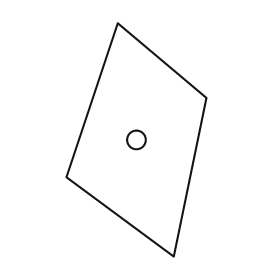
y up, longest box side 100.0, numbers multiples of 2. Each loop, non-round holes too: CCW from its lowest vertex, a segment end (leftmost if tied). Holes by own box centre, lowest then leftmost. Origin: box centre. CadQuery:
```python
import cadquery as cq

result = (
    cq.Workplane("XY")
    .moveTo(16.0, -50.0)
    .lineTo(30.0, 18.0)
    .lineTo(-8.0, 50.0)
    .lineTo(-30.0, -16.0)
    .close()
    .moveTo(0.0, 0.0)
    .circle(4.0)
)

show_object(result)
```